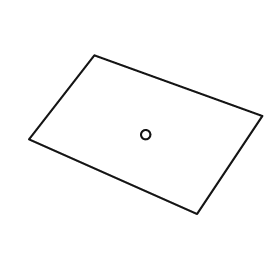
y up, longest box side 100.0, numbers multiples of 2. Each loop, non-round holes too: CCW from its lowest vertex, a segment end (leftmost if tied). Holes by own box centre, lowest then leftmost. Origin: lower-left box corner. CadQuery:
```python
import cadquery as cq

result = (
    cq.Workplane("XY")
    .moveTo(72.0, 0.0)
    .lineTo(100.0, 42.0)
    .lineTo(28.0, 68.0)
    .lineTo(0.0, 32.0)
    .close()
    .moveTo(50.0, 34.0)
    .circle(2.0)
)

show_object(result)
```